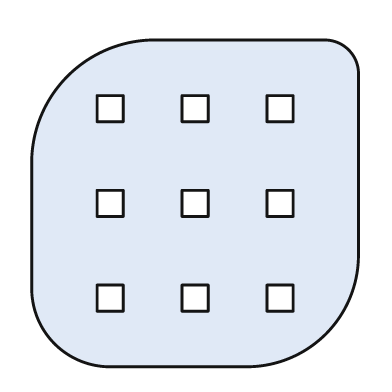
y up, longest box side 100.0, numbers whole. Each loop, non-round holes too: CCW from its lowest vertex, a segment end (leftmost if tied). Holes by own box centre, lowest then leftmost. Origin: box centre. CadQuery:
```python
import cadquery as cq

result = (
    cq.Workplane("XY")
    .moveTo(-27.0, -50.0)
    .lineTo(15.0, -50.0)
    .threePointArc((40.0, -40.0), (50.0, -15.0))
    .lineTo(50.0, 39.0)
    .threePointArc((47.0, 47.0), (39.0, 50.0))
    .lineTo(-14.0, 50.0)
    .threePointArc((-39.0, 39.0), (-50.0, 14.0))
    .lineTo(-50.0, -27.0)
    .threePointArc((-43.0, -43.0), (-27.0, -50.0))
    .close()
    .moveTo(-30.0, -33.0)
    .lineTo(-22.0, -33.0)
    .lineTo(-22.0, -25.0)
    .lineTo(-30.0, -25.0)
    .close()
    .moveTo(-4.0, -33.0)
    .lineTo(4.0, -33.0)
    .lineTo(4.0, -25.0)
    .lineTo(-4.0, -25.0)
    .close()
    .moveTo(22.0, -33.0)
    .lineTo(30.0, -33.0)
    .lineTo(30.0, -25.0)
    .lineTo(22.0, -25.0)
    .close()
    .moveTo(-30.0, -4.0)
    .lineTo(-22.0, -4.0)
    .lineTo(-22.0, 4.0)
    .lineTo(-30.0, 4.0)
    .close()
    .moveTo(-4.0, -4.0)
    .lineTo(4.0, -4.0)
    .lineTo(4.0, 4.0)
    .lineTo(-4.0, 4.0)
    .close()
    .moveTo(22.0, -4.0)
    .lineTo(30.0, -4.0)
    .lineTo(30.0, 4.0)
    .lineTo(22.0, 4.0)
    .close()
    .moveTo(-30.0, 25.0)
    .lineTo(-22.0, 25.0)
    .lineTo(-22.0, 33.0)
    .lineTo(-30.0, 33.0)
    .close()
    .moveTo(-4.0, 25.0)
    .lineTo(4.0, 25.0)
    .lineTo(4.0, 33.0)
    .lineTo(-4.0, 33.0)
    .close()
    .moveTo(22.0, 25.0)
    .lineTo(30.0, 25.0)
    .lineTo(30.0, 33.0)
    .lineTo(22.0, 33.0)
    .close()
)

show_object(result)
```